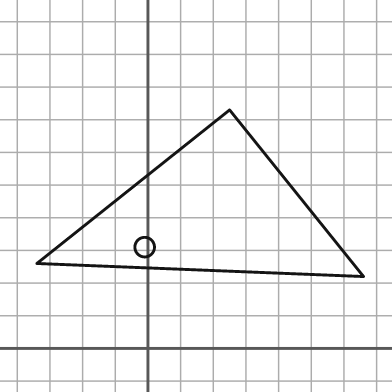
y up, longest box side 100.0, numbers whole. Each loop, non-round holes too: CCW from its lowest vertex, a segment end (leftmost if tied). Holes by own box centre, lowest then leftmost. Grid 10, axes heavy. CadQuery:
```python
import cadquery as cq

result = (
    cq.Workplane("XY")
    .moveTo(66.0, 22.0)
    .lineTo(25.0, 73.0)
    .lineTo(-34.0, 26.0)
    .close()
    .moveTo(-1.0, 31.0)
    .circle(3.0)
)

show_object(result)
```